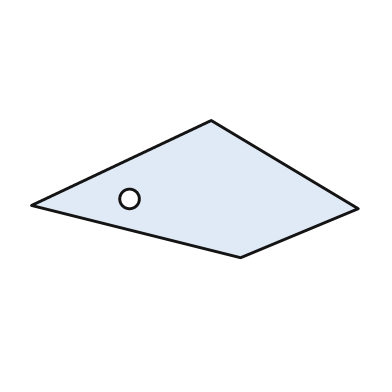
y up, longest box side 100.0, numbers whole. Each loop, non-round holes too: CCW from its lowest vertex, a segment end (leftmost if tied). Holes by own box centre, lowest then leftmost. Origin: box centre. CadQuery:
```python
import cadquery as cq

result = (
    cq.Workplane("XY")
    .moveTo(14.0, -21.0)
    .lineTo(50.0, -6.0)
    .lineTo(5.0, 21.0)
    .lineTo(-50.0, -5.0)
    .close()
    .moveTo(-20.0, -3.0)
    .circle(3.0)
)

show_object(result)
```